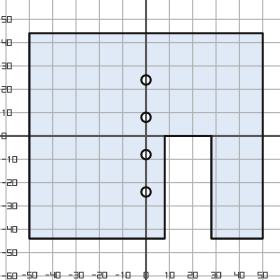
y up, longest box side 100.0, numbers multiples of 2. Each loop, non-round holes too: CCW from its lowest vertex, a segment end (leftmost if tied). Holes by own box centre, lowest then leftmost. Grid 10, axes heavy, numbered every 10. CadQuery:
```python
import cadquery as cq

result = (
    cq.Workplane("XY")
    .moveTo(-50.0, -44.0)
    .lineTo(8.0, -44.0)
    .lineTo(8.0, 0.0)
    .lineTo(28.0, 0.0)
    .lineTo(28.0, -44.0)
    .lineTo(50.0, -44.0)
    .lineTo(50.0, 44.0)
    .lineTo(-50.0, 44.0)
    .close()
    .moveTo(0.0, -24.0)
    .circle(2.0)
    .moveTo(0.0, -8.0)
    .circle(2.0)
    .moveTo(0.0, 8.0)
    .circle(2.0)
    .moveTo(0.0, 24.0)
    .circle(2.0)
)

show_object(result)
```